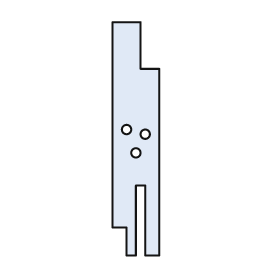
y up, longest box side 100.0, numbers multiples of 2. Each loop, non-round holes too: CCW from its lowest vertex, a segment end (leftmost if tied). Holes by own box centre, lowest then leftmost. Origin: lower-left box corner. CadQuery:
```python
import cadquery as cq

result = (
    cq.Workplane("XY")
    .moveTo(6.0, 0.0)
    .lineTo(10.0, 0.0)
    .lineTo(10.0, 30.0)
    .lineTo(14.0, 30.0)
    .lineTo(14.0, 0.0)
    .lineTo(20.0, 0.0)
    .lineTo(20.0, 80.0)
    .lineTo(12.0, 80.0)
    .lineTo(12.0, 100.0)
    .lineTo(0.0, 100.0)
    .lineTo(0.0, 12.0)
    .lineTo(6.0, 12.0)
    .close()
    .moveTo(10.0, 44.0)
    .circle(2.0)
    .moveTo(14.0, 52.0)
    .circle(2.0)
    .moveTo(6.0, 54.0)
    .circle(2.0)
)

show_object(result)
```